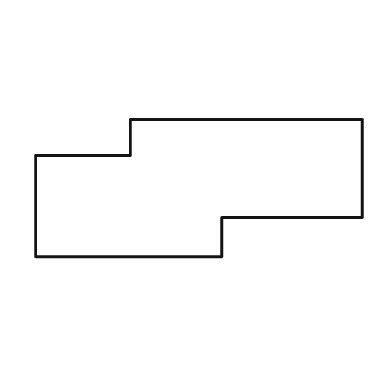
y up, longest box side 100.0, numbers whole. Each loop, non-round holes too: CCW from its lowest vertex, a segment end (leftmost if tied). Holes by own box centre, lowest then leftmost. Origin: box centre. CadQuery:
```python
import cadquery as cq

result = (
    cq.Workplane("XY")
    .moveTo(-50.0, -21.0)
    .lineTo(7.0, -21.0)
    .lineTo(7.0, -9.0)
    .lineTo(50.0, -9.0)
    .lineTo(50.0, 21.0)
    .lineTo(-21.0, 21.0)
    .lineTo(-21.0, 10.0)
    .lineTo(-50.0, 10.0)
    .close()
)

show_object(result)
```